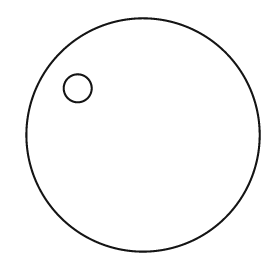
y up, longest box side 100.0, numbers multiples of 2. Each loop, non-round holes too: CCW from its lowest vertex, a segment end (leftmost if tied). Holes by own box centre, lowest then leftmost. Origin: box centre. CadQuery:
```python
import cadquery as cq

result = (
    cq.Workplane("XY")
    .moveTo(0.0, 0.0)
    .circle(50.0)
    .moveTo(-28.0, 20.0)
    .circle(6.0)
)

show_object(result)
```